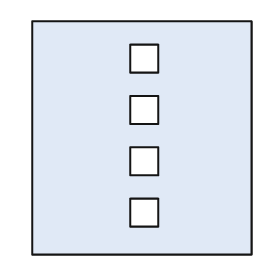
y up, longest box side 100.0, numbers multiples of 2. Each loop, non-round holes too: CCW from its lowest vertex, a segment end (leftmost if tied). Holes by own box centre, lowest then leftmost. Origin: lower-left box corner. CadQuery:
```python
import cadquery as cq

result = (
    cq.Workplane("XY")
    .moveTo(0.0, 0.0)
    .lineTo(94.0, 0.0)
    .lineTo(94.0, 100.0)
    .lineTo(0.0, 100.0)
    .close()
    .moveTo(42.0, 12.0)
    .lineTo(54.0, 12.0)
    .lineTo(54.0, 24.0)
    .lineTo(42.0, 24.0)
    .close()
    .moveTo(42.0, 34.0)
    .lineTo(54.0, 34.0)
    .lineTo(54.0, 46.0)
    .lineTo(42.0, 46.0)
    .close()
    .moveTo(42.0, 56.0)
    .lineTo(54.0, 56.0)
    .lineTo(54.0, 68.0)
    .lineTo(42.0, 68.0)
    .close()
    .moveTo(42.0, 78.0)
    .lineTo(54.0, 78.0)
    .lineTo(54.0, 90.0)
    .lineTo(42.0, 90.0)
    .close()
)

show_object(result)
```